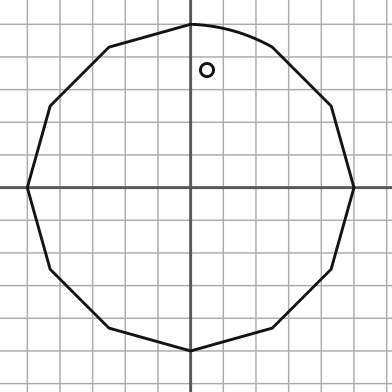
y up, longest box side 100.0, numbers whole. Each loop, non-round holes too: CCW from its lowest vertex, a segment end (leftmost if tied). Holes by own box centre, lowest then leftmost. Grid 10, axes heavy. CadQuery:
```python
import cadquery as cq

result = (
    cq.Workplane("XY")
    .moveTo(0.0, -50.0)
    .lineTo(25.0, -43.0)
    .lineTo(43.0, -25.0)
    .lineTo(50.0, 0.0)
    .lineTo(43.0, 25.0)
    .lineTo(25.0, 43.0)
    .threePointArc((13.0, 48.0), (0.0, 50.0))
    .lineTo(-25.0, 43.0)
    .lineTo(-43.0, 25.0)
    .lineTo(-50.0, 0.0)
    .lineTo(-43.0, -25.0)
    .lineTo(-25.0, -43.0)
    .close()
    .moveTo(5.0, 36.0)
    .circle(2.0)
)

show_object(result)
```